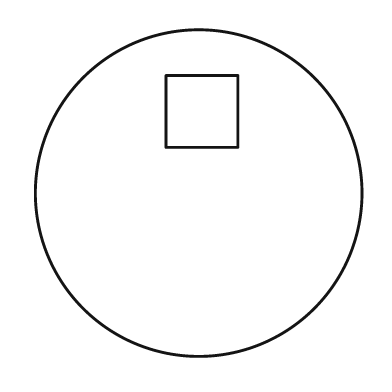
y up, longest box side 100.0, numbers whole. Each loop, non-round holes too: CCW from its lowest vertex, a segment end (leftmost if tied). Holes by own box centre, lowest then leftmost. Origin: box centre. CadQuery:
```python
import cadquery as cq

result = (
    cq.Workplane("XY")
    .moveTo(0.0, 0.0)
    .circle(50.0)
    .moveTo(-10.0, 14.0)
    .lineTo(12.0, 14.0)
    .lineTo(12.0, 36.0)
    .lineTo(-10.0, 36.0)
    .close()
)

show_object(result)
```